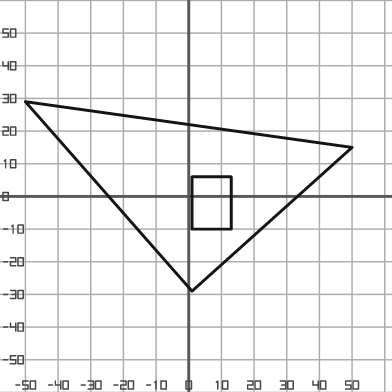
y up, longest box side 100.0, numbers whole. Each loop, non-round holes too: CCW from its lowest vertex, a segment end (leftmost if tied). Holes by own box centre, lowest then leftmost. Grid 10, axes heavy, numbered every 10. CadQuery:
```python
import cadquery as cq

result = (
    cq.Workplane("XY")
    .moveTo(1.0, -29.0)
    .lineTo(50.0, 15.0)
    .lineTo(-50.0, 29.0)
    .close()
    .moveTo(1.0, -10.0)
    .lineTo(13.0, -10.0)
    .lineTo(13.0, 6.0)
    .lineTo(1.0, 6.0)
    .close()
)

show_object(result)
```